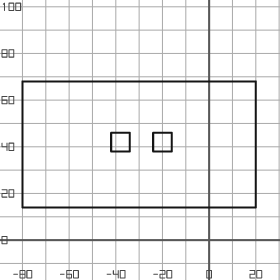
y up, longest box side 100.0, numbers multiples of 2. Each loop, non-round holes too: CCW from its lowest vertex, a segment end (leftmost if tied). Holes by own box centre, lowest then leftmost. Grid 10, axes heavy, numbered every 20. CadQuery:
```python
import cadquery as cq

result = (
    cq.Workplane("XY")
    .moveTo(-80.0, 14.0)
    .lineTo(20.0, 14.0)
    .lineTo(20.0, 68.0)
    .lineTo(-80.0, 68.0)
    .close()
    .moveTo(-42.0, 38.0)
    .lineTo(-34.0, 38.0)
    .lineTo(-34.0, 46.0)
    .lineTo(-42.0, 46.0)
    .close()
    .moveTo(-24.0, 38.0)
    .lineTo(-16.0, 38.0)
    .lineTo(-16.0, 46.0)
    .lineTo(-24.0, 46.0)
    .close()
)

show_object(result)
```